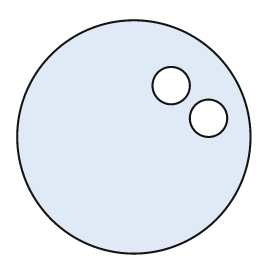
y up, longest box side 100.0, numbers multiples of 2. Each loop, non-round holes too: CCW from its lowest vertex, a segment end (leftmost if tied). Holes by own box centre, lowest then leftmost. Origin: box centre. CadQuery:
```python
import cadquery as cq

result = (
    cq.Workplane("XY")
    .moveTo(0.0, 0.0)
    .circle(50.0)
    .moveTo(32.0, 8.0)
    .circle(8.0)
    .moveTo(16.0, 22.0)
    .circle(8.0)
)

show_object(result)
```